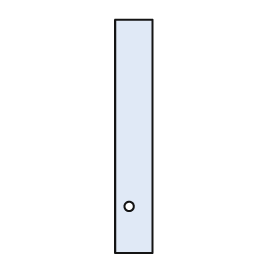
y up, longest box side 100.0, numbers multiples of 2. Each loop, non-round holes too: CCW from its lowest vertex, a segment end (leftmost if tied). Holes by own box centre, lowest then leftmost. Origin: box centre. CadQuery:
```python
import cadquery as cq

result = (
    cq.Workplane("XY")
    .moveTo(-8.0, -50.0)
    .lineTo(8.0, -50.0)
    .lineTo(8.0, 50.0)
    .lineTo(-8.0, 50.0)
    .close()
    .moveTo(-2.0, -30.0)
    .circle(2.0)
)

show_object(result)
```